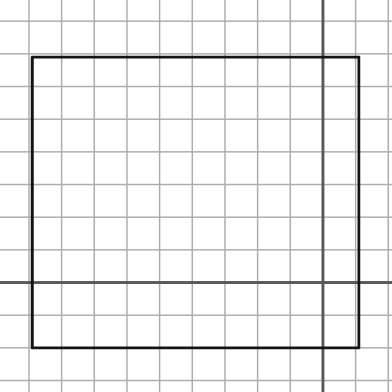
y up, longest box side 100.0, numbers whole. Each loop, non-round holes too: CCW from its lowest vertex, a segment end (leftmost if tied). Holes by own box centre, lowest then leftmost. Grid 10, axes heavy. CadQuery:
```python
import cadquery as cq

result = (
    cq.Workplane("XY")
    .moveTo(-89.0, -20.0)
    .lineTo(11.0, -20.0)
    .lineTo(11.0, 69.0)
    .lineTo(-89.0, 69.0)
    .close()
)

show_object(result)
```